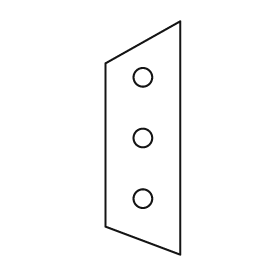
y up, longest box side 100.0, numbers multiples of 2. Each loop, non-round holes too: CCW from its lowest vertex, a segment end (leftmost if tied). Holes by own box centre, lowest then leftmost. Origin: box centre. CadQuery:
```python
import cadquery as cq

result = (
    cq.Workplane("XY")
    .moveTo(16.0, -50.0)
    .lineTo(16.0, 50.0)
    .lineTo(-16.0, 32.0)
    .lineTo(-16.0, -38.0)
    .close()
    .moveTo(0.0, -26.0)
    .circle(4.0)
    .moveTo(0.0, 0.0)
    .circle(4.0)
    .moveTo(0.0, 26.0)
    .circle(4.0)
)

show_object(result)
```